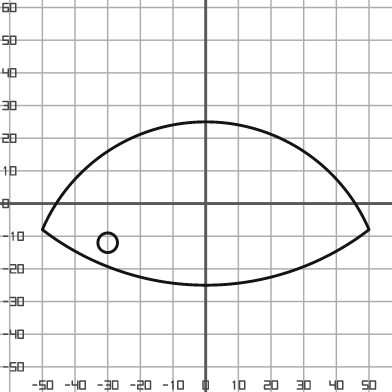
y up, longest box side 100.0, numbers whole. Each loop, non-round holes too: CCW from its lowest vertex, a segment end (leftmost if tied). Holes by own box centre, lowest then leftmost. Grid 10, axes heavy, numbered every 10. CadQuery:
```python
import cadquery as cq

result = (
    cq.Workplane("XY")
    .moveTo(-50.0, -8.0)
    .threePointArc((0.0, -25.0), (50.0, -8.0))
    .threePointArc((0.0, 25.0), (-50.0, -8.0))
    .close()
    .moveTo(-30.0, -12.0)
    .circle(3.0)
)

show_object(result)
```